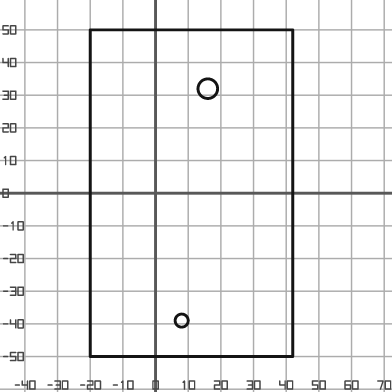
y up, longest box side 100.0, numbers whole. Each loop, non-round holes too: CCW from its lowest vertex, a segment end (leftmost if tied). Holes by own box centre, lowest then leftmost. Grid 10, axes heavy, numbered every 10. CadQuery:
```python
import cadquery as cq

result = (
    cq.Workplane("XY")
    .moveTo(-20.0, -50.0)
    .lineTo(42.0, -50.0)
    .lineTo(42.0, 50.0)
    .lineTo(-20.0, 50.0)
    .close()
    .moveTo(8.0, -39.0)
    .circle(2.0)
    .moveTo(16.0, 32.0)
    .circle(3.0)
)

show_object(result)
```